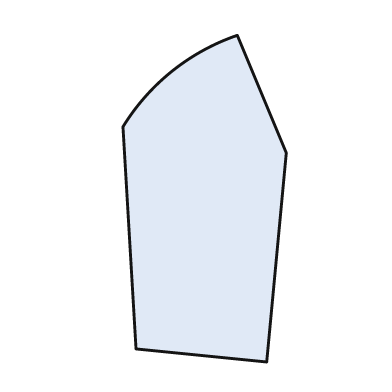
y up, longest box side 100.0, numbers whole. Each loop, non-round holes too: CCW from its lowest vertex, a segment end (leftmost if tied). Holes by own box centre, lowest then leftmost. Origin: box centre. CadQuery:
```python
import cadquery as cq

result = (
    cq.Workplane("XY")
    .moveTo(19.0, -50.0)
    .lineTo(25.0, 14.0)
    .lineTo(10.0, 50.0)
    .threePointArc((-10.0, 39.0), (-25.0, 22.0))
    .lineTo(-21.0, -46.0)
    .close()
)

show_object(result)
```